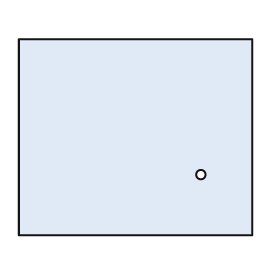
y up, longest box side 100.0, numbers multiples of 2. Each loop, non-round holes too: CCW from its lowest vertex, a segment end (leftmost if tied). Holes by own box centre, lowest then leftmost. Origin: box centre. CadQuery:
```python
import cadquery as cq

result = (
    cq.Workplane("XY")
    .moveTo(-50.0, -42.0)
    .lineTo(50.0, -42.0)
    .lineTo(50.0, 42.0)
    .lineTo(-50.0, 42.0)
    .close()
    .moveTo(28.0, -16.0)
    .circle(2.0)
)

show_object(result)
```